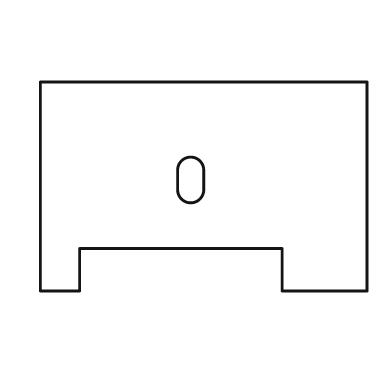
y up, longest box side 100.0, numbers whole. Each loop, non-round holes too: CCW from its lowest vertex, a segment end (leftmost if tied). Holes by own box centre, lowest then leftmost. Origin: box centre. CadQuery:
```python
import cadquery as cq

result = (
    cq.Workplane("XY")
    .moveTo(-50.0, -32.0)
    .lineTo(-38.0, -32.0)
    .lineTo(-38.0, -19.0)
    .lineTo(24.0, -19.0)
    .lineTo(24.0, -32.0)
    .lineTo(50.0, -32.0)
    .lineTo(50.0, 32.0)
    .lineTo(-50.0, 32.0)
    .close()
    .moveTo(-8.0, -1.0)
    .threePointArc((-4.0, -5.0), (0.0, -1.0))
    .lineTo(0.0, 5.0)
    .threePointArc((-4.0, 9.0), (-8.0, 5.0))
    .close()
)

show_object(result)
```